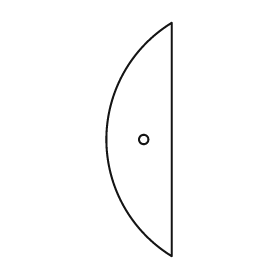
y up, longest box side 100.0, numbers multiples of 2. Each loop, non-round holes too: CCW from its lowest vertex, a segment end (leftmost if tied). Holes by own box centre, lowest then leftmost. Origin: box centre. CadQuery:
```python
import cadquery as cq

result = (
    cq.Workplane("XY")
    .moveTo(14.0, -50.0)
    .lineTo(14.0, 50.0)
    .threePointArc((-14.0, 0.0), (14.0, -50.0))
    .close()
    .moveTo(2.0, 0.0)
    .circle(2.0)
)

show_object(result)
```